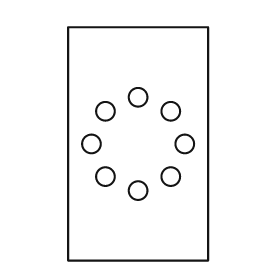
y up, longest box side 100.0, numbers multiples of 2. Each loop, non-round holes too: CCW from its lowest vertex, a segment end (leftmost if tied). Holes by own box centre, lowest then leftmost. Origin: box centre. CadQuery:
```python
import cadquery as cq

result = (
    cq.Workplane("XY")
    .moveTo(-30.0, -50.0)
    .lineTo(30.0, -50.0)
    .lineTo(30.0, 50.0)
    .lineTo(-30.0, 50.0)
    .close()
    .moveTo(0.0, -20.0)
    .circle(4.0)
    .moveTo(-14.0, -14.0)
    .circle(4.0)
    .moveTo(14.0, -14.0)
    .circle(4.0)
    .moveTo(-20.0, 0.0)
    .circle(4.0)
    .moveTo(20.0, 0.0)
    .circle(4.0)
    .moveTo(-14.0, 14.0)
    .circle(4.0)
    .moveTo(14.0, 14.0)
    .circle(4.0)
    .moveTo(0.0, 20.0)
    .circle(4.0)
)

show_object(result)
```